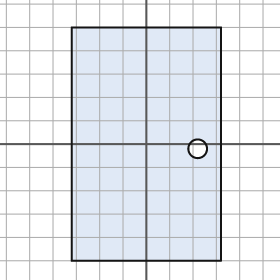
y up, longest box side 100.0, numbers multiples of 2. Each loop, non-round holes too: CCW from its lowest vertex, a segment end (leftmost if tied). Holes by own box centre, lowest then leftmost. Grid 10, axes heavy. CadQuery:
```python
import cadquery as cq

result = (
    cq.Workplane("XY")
    .moveTo(-32.0, -50.0)
    .lineTo(32.0, -50.0)
    .lineTo(32.0, 50.0)
    .lineTo(-32.0, 50.0)
    .close()
    .moveTo(22.0, -2.0)
    .circle(4.0)
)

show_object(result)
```